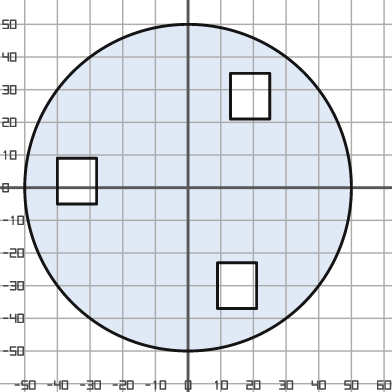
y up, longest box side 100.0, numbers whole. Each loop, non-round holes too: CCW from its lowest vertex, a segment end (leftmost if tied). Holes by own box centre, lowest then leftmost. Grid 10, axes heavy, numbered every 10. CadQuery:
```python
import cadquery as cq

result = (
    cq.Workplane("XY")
    .moveTo(0.0, 0.0)
    .circle(50.0)
    .moveTo(9.0, -37.0)
    .lineTo(21.0, -37.0)
    .lineTo(21.0, -23.0)
    .lineTo(9.0, -23.0)
    .close()
    .moveTo(-40.0, -5.0)
    .lineTo(-28.0, -5.0)
    .lineTo(-28.0, 9.0)
    .lineTo(-40.0, 9.0)
    .close()
    .moveTo(13.0, 21.0)
    .lineTo(25.0, 21.0)
    .lineTo(25.0, 35.0)
    .lineTo(13.0, 35.0)
    .close()
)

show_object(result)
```